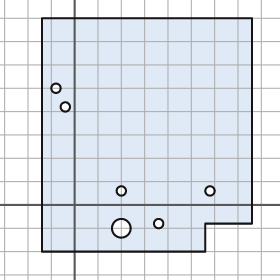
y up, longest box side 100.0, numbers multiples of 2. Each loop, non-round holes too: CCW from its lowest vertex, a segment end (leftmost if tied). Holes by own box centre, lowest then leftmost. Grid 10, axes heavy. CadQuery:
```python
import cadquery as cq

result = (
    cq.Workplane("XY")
    .moveTo(-14.0, -20.0)
    .lineTo(56.0, -20.0)
    .lineTo(56.0, -8.0)
    .lineTo(76.0, -8.0)
    .lineTo(76.0, 80.0)
    .lineTo(-14.0, 80.0)
    .close()
    .moveTo(20.0, -10.0)
    .circle(4.0)
    .moveTo(36.0, -8.0)
    .circle(2.0)
    .moveTo(20.0, 6.0)
    .circle(2.0)
    .moveTo(58.0, 6.0)
    .circle(2.0)
    .moveTo(-4.0, 42.0)
    .circle(2.0)
    .moveTo(-8.0, 50.0)
    .circle(2.0)
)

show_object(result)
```